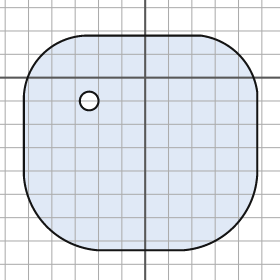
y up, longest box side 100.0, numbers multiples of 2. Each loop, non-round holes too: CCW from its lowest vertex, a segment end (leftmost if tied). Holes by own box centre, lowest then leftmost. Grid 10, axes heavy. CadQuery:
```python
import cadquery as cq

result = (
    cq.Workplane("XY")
    .moveTo(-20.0, -74.0)
    .lineTo(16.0, -74.0)
    .threePointArc((38.0, -64.0), (48.0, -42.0))
    .lineTo(48.0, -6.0)
    .threePointArc((40.0, 10.0), (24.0, 18.0))
    .lineTo(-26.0, 18.0)
    .threePointArc((-44.0, 10.0), (-52.0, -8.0))
    .lineTo(-52.0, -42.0)
    .threePointArc((-42.0, -64.0), (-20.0, -74.0))
    .close()
    .moveTo(-24.0, -10.0)
    .circle(4.0)
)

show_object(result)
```